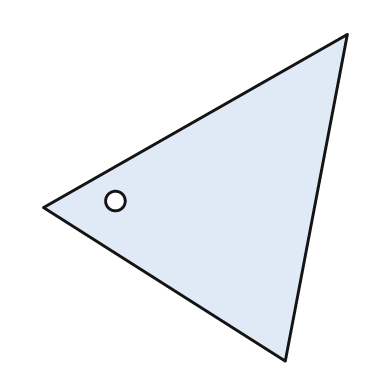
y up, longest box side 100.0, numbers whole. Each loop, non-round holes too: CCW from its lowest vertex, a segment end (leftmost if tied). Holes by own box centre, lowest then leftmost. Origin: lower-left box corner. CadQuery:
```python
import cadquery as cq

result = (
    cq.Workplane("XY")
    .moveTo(74.0, 0.0)
    .lineTo(93.0, 100.0)
    .lineTo(0.0, 47.0)
    .close()
    .moveTo(22.0, 49.0)
    .circle(3.0)
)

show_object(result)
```